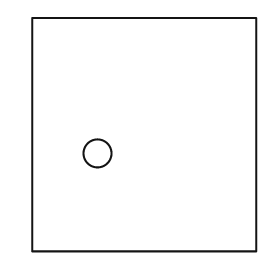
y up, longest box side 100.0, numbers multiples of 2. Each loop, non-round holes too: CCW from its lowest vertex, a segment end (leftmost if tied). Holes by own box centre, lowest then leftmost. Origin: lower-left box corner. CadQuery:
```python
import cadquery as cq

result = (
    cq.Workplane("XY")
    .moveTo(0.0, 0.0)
    .lineTo(96.0, 0.0)
    .lineTo(96.0, 100.0)
    .lineTo(0.0, 100.0)
    .close()
    .moveTo(28.0, 42.0)
    .circle(6.0)
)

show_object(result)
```